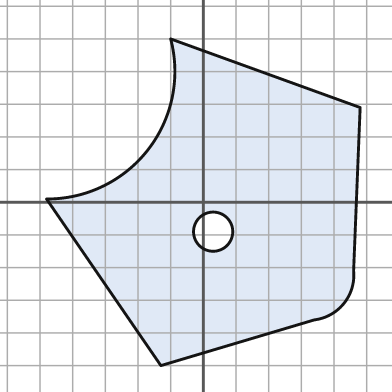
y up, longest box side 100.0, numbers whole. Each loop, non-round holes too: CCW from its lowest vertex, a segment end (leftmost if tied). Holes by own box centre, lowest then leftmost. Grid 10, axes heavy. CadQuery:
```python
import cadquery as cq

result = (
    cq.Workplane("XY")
    .moveTo(-13.0, -50.0)
    .lineTo(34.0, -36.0)
    .threePointArc((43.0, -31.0), (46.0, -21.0))
    .lineTo(48.0, 29.0)
    .lineTo(-10.0, 50.0)
    .threePointArc((-17.0, 16.0), (-48.0, 1.0))
    .close()
    .moveTo(3.0, -9.0)
    .circle(6.0)
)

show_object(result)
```